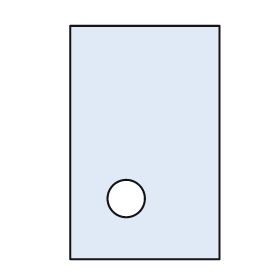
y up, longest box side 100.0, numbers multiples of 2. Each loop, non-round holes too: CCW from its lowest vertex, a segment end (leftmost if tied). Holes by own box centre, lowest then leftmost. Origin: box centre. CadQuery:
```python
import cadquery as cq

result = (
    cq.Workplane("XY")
    .moveTo(-32.0, -50.0)
    .lineTo(32.0, -50.0)
    .lineTo(32.0, 50.0)
    .lineTo(-32.0, 50.0)
    .close()
    .moveTo(-8.0, -24.0)
    .circle(8.0)
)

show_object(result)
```